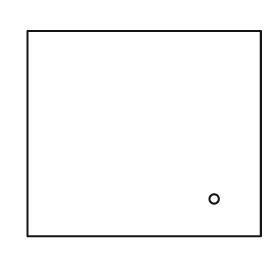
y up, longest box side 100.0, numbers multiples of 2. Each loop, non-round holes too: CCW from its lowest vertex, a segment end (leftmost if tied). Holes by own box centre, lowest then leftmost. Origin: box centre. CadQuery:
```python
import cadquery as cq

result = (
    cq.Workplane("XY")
    .moveTo(-50.0, -44.0)
    .lineTo(50.0, -44.0)
    .lineTo(50.0, 44.0)
    .lineTo(-50.0, 44.0)
    .close()
    .moveTo(30.0, -28.0)
    .circle(2.0)
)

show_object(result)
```